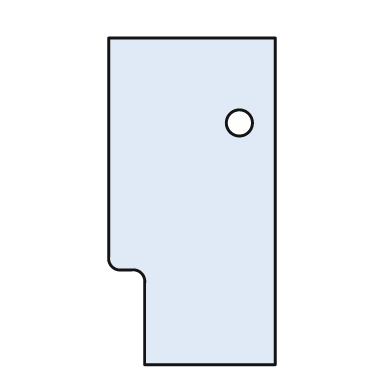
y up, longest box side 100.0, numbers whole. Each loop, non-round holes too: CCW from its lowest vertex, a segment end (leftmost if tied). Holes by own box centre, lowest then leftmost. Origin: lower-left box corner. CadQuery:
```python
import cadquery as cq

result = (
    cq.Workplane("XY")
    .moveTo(11.0, 0.0)
    .lineTo(51.0, 0.0)
    .lineTo(51.0, 100.0)
    .lineTo(0.0, 100.0)
    .lineTo(0.0, 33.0)
    .threePointArc((1.0, 30.0), (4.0, 29.0))
    .lineTo(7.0, 29.0)
    .threePointArc((10.0, 28.0), (11.0, 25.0))
    .close()
    .moveTo(40.0, 74.0)
    .circle(4.0)
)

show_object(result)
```